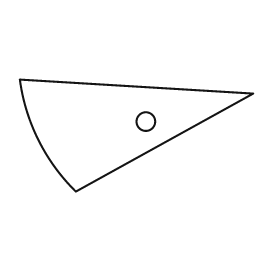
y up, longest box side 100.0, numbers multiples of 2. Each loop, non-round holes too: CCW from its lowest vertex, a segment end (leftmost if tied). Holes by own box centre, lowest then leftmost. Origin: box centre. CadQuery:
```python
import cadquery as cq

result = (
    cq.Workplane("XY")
    .moveTo(-26.0, -24.0)
    .lineTo(50.0, 18.0)
    .lineTo(-50.0, 24.0)
    .threePointArc((-42.0, -2.0), (-26.0, -24.0))
    .close()
    .moveTo(4.0, 6.0)
    .circle(4.0)
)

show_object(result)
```